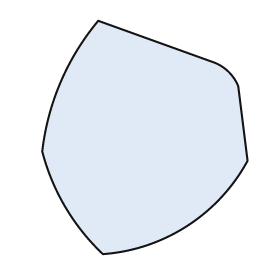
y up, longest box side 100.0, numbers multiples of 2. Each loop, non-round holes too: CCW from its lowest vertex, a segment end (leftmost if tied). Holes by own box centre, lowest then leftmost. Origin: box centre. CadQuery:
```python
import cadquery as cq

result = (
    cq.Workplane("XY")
    .moveTo(-18.0, -50.0)
    .threePointArc((18.0, -38.0), (44.0, -10.0))
    .lineTo(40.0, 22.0)
    .threePointArc((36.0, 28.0), (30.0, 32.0))
    .lineTo(-20.0, 50.0)
    .threePointArc((-36.0, 24.0), (-44.0, -6.0))
    .threePointArc((-34.0, -30.0), (-18.0, -50.0))
    .close()
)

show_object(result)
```